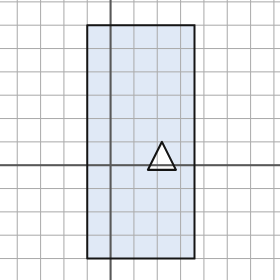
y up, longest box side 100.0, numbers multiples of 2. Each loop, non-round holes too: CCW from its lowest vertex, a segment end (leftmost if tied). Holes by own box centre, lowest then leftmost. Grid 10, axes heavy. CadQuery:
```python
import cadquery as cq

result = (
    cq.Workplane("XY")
    .moveTo(-10.0, -40.0)
    .lineTo(36.0, -40.0)
    .lineTo(36.0, 60.0)
    .lineTo(-10.0, 60.0)
    .close()
    .moveTo(16.0, -2.0)
    .lineTo(28.0, -2.0)
    .lineTo(22.0, 10.0)
    .close()
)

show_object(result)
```